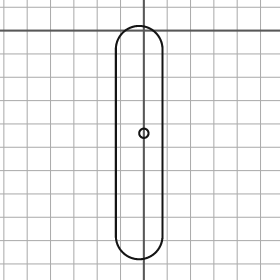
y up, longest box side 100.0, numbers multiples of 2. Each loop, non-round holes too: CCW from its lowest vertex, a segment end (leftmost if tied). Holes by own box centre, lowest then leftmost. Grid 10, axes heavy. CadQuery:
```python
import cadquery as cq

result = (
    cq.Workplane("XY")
    .moveTo(-12.0, -88.0)
    .threePointArc((-2.0, -98.0), (8.0, -88.0))
    .lineTo(8.0, -8.0)
    .threePointArc((-2.0, 2.0), (-12.0, -8.0))
    .close()
    .moveTo(0.0, -44.0)
    .circle(2.0)
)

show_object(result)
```